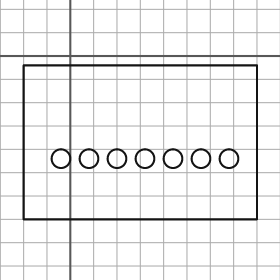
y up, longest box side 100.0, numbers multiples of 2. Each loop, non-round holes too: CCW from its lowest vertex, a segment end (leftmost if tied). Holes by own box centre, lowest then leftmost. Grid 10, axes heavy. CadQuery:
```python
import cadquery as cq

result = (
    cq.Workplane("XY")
    .moveTo(-20.0, -70.0)
    .lineTo(80.0, -70.0)
    .lineTo(80.0, -4.0)
    .lineTo(-20.0, -4.0)
    .close()
    .moveTo(-4.0, -44.0)
    .circle(4.0)
    .moveTo(8.0, -44.0)
    .circle(4.0)
    .moveTo(20.0, -44.0)
    .circle(4.0)
    .moveTo(32.0, -44.0)
    .circle(4.0)
    .moveTo(44.0, -44.0)
    .circle(4.0)
    .moveTo(56.0, -44.0)
    .circle(4.0)
    .moveTo(68.0, -44.0)
    .circle(4.0)
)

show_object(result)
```